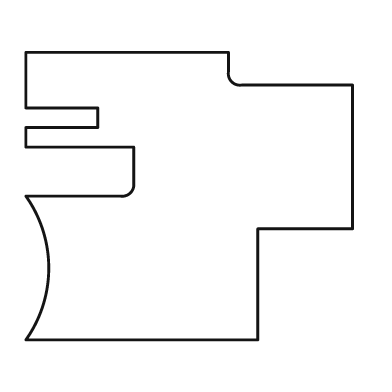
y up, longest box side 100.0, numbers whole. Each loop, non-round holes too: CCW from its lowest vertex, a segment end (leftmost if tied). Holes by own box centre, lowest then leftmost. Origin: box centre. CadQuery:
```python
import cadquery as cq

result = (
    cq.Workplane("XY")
    .moveTo(-50.0, -44.0)
    .lineTo(21.0, -44.0)
    .lineTo(21.0, -10.0)
    .lineTo(50.0, -10.0)
    .lineTo(50.0, 34.0)
    .lineTo(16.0, 34.0)
    .threePointArc((13.0, 35.0), (12.0, 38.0))
    .lineTo(12.0, 44.0)
    .lineTo(-50.0, 44.0)
    .lineTo(-50.0, 27.0)
    .lineTo(-28.0, 27.0)
    .lineTo(-28.0, 21.0)
    .lineTo(-50.0, 21.0)
    .lineTo(-50.0, 15.0)
    .lineTo(-17.0, 15.0)
    .lineTo(-17.0, 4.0)
    .threePointArc((-18.0, 1.0), (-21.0, 0.0))
    .lineTo(-50.0, 0.0)
    .threePointArc((-43.0, -22.0), (-50.0, -44.0))
    .close()
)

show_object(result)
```